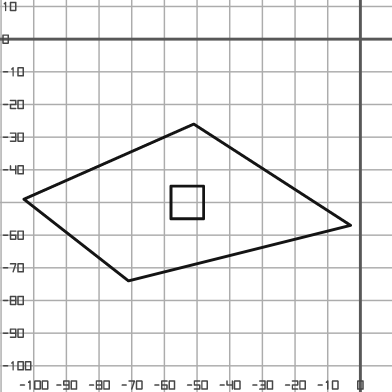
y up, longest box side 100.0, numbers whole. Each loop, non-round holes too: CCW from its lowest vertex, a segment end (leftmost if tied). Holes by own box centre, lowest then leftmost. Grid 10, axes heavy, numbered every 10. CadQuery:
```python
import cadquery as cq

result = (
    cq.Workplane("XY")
    .moveTo(-71.0, -74.0)
    .lineTo(-3.0, -57.0)
    .lineTo(-51.0, -26.0)
    .lineTo(-103.0, -49.0)
    .close()
    .moveTo(-58.0, -55.0)
    .lineTo(-48.0, -55.0)
    .lineTo(-48.0, -45.0)
    .lineTo(-58.0, -45.0)
    .close()
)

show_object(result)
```